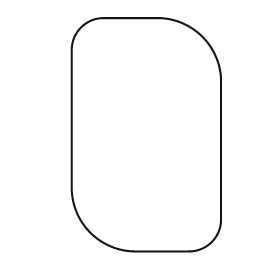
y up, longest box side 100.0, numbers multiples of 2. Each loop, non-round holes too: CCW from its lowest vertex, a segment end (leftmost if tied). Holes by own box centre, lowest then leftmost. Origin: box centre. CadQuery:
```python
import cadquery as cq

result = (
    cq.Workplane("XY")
    .moveTo(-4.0, -50.0)
    .lineTo(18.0, -50.0)
    .threePointArc((28.0, -46.0), (32.0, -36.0))
    .lineTo(32.0, 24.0)
    .threePointArc((24.0, 42.0), (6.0, 50.0))
    .lineTo(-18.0, 50.0)
    .threePointArc((-28.0, 46.0), (-32.0, 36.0))
    .lineTo(-32.0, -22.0)
    .threePointArc((-24.0, -42.0), (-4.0, -50.0))
    .close()
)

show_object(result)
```